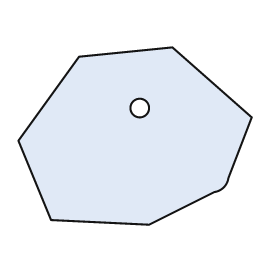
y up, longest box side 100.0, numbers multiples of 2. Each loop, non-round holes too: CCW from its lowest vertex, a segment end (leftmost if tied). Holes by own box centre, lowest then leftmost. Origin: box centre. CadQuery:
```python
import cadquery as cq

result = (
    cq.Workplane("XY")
    .moveTo(6.0, -38.0)
    .lineTo(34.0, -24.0)
    .threePointArc((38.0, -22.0), (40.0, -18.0))
    .lineTo(50.0, 8.0)
    .lineTo(16.0, 38.0)
    .lineTo(-24.0, 34.0)
    .lineTo(-50.0, -2.0)
    .lineTo(-36.0, -36.0)
    .close()
    .moveTo(2.0, 12.0)
    .circle(4.0)
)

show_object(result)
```